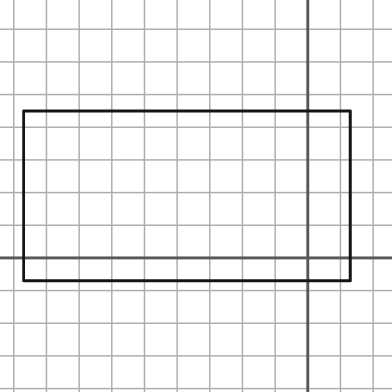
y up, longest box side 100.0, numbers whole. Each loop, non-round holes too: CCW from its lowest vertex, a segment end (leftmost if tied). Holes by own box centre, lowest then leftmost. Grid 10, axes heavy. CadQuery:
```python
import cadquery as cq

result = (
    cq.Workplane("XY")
    .moveTo(-87.0, -7.0)
    .lineTo(13.0, -7.0)
    .lineTo(13.0, 45.0)
    .lineTo(-87.0, 45.0)
    .close()
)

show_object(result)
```